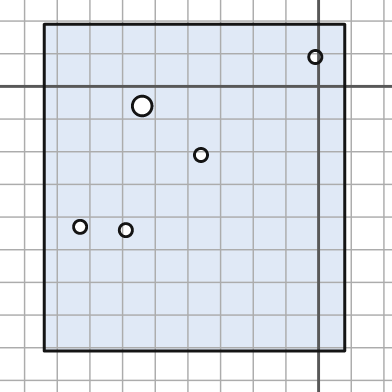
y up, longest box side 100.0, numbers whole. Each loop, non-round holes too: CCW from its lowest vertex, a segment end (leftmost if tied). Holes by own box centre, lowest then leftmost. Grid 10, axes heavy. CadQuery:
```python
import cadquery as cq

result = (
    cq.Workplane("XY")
    .moveTo(-84.0, -81.0)
    .lineTo(8.0, -81.0)
    .lineTo(8.0, 19.0)
    .lineTo(-84.0, 19.0)
    .close()
    .moveTo(-59.0, -44.0)
    .circle(2.0)
    .moveTo(-73.0, -43.0)
    .circle(2.0)
    .moveTo(-36.0, -21.0)
    .circle(2.0)
    .moveTo(-54.0, -6.0)
    .circle(3.0)
    .moveTo(-1.0, 9.0)
    .circle(2.0)
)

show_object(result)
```